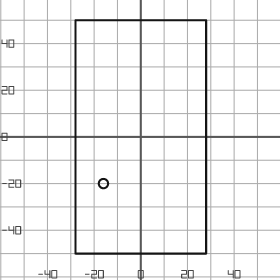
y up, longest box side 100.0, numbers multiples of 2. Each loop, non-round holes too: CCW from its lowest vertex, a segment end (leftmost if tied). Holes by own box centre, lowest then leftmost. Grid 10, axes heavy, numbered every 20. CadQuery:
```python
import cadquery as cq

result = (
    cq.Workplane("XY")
    .moveTo(-28.0, -50.0)
    .lineTo(28.0, -50.0)
    .lineTo(28.0, 50.0)
    .lineTo(-28.0, 50.0)
    .close()
    .moveTo(-16.0, -20.0)
    .circle(2.0)
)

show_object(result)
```